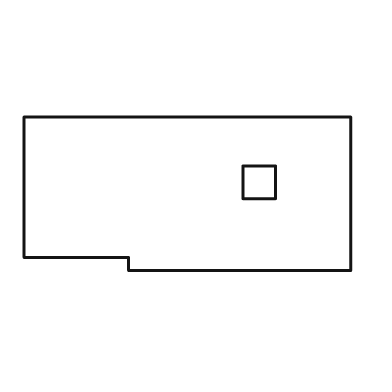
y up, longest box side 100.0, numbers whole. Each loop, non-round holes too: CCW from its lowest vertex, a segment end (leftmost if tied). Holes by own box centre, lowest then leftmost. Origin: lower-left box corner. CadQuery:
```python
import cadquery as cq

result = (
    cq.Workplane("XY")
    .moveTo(32.0, 0.0)
    .lineTo(100.0, 0.0)
    .lineTo(100.0, 47.0)
    .lineTo(0.0, 47.0)
    .lineTo(0.0, 4.0)
    .lineTo(32.0, 4.0)
    .close()
    .moveTo(67.0, 22.0)
    .lineTo(77.0, 22.0)
    .lineTo(77.0, 32.0)
    .lineTo(67.0, 32.0)
    .close()
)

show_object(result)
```